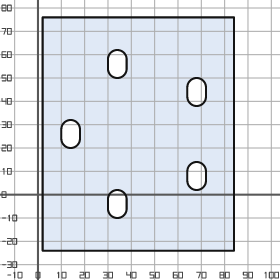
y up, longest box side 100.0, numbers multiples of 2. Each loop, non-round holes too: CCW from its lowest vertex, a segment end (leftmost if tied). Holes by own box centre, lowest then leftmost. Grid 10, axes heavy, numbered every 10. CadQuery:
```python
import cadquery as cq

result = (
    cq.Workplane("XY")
    .moveTo(2.0, -24.0)
    .lineTo(84.0, -24.0)
    .lineTo(84.0, 76.0)
    .lineTo(2.0, 76.0)
    .close()
    .moveTo(30.0, -6.0)
    .threePointArc((34.0, -10.0), (38.0, -6.0))
    .lineTo(38.0, -2.0)
    .threePointArc((34.0, 2.0), (30.0, -2.0))
    .close()
    .moveTo(64.0, 6.0)
    .threePointArc((68.0, 2.0), (72.0, 6.0))
    .lineTo(72.0, 10.0)
    .threePointArc((68.0, 14.0), (64.0, 10.0))
    .close()
    .moveTo(10.0, 24.0)
    .threePointArc((14.0, 20.0), (18.0, 24.0))
    .lineTo(18.0, 28.0)
    .threePointArc((14.0, 32.0), (10.0, 28.0))
    .close()
    .moveTo(64.0, 42.0)
    .threePointArc((68.0, 38.0), (72.0, 42.0))
    .lineTo(72.0, 46.0)
    .threePointArc((68.0, 50.0), (64.0, 46.0))
    .close()
    .moveTo(30.0, 54.0)
    .threePointArc((34.0, 50.0), (38.0, 54.0))
    .lineTo(38.0, 58.0)
    .threePointArc((34.0, 62.0), (30.0, 58.0))
    .close()
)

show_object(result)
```